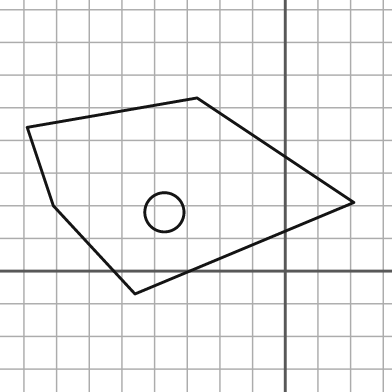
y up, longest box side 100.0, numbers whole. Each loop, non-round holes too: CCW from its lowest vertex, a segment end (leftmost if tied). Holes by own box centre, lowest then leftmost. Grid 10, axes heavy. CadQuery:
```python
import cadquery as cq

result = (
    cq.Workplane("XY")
    .moveTo(-46.0, -7.0)
    .lineTo(21.0, 21.0)
    .lineTo(-27.0, 53.0)
    .lineTo(-79.0, 44.0)
    .lineTo(-71.0, 20.0)
    .close()
    .moveTo(-37.0, 18.0)
    .circle(6.0)
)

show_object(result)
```